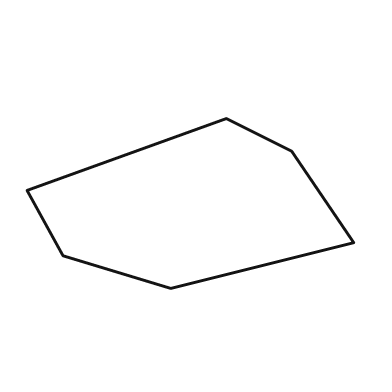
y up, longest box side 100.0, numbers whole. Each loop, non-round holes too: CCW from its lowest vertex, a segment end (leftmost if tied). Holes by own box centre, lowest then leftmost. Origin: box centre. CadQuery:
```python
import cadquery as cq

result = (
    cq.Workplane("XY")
    .moveTo(-6.0, -26.0)
    .lineTo(50.0, -12.0)
    .lineTo(31.0, 16.0)
    .lineTo(11.0, 26.0)
    .lineTo(-50.0, 4.0)
    .lineTo(-39.0, -16.0)
    .close()
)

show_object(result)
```